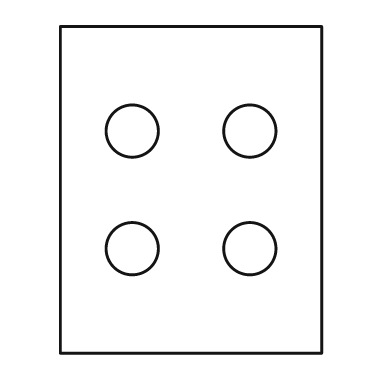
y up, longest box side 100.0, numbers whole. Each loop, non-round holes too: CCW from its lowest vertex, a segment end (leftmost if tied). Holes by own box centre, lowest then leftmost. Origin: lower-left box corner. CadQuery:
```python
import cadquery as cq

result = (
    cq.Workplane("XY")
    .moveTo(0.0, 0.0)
    .lineTo(80.0, 0.0)
    .lineTo(80.0, 100.0)
    .lineTo(0.0, 100.0)
    .close()
    .moveTo(22.0, 32.0)
    .circle(8.0)
    .moveTo(58.0, 32.0)
    .circle(8.0)
    .moveTo(22.0, 68.0)
    .circle(8.0)
    .moveTo(58.0, 68.0)
    .circle(8.0)
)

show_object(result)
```